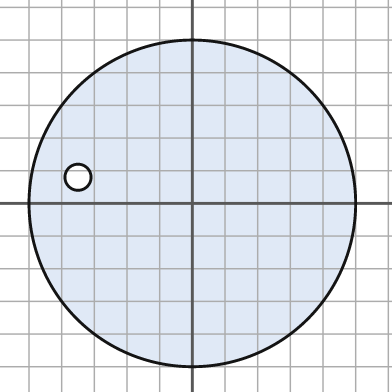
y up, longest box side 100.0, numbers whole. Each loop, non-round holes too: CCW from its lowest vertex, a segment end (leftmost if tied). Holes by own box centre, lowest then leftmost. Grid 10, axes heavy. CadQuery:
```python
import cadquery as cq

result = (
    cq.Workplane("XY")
    .moveTo(0.0, 0.0)
    .circle(50.0)
    .moveTo(-35.0, 8.0)
    .circle(4.0)
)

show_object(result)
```